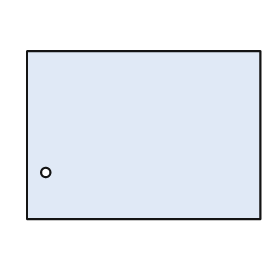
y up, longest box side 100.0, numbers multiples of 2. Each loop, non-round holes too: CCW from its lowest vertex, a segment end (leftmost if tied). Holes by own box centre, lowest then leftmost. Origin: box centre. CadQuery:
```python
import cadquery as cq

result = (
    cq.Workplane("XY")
    .moveTo(-50.0, -36.0)
    .lineTo(50.0, -36.0)
    .lineTo(50.0, 36.0)
    .lineTo(-50.0, 36.0)
    .close()
    .moveTo(-42.0, -16.0)
    .circle(2.0)
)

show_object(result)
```